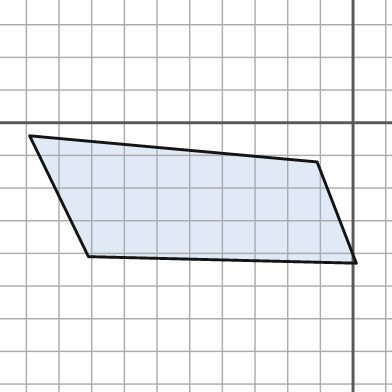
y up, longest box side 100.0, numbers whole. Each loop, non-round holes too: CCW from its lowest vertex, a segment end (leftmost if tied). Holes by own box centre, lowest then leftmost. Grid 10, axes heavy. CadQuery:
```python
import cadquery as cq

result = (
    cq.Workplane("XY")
    .moveTo(1.0, -43.0)
    .lineTo(-11.0, -12.0)
    .lineTo(-99.0, -4.0)
    .lineTo(-81.0, -41.0)
    .close()
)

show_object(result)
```